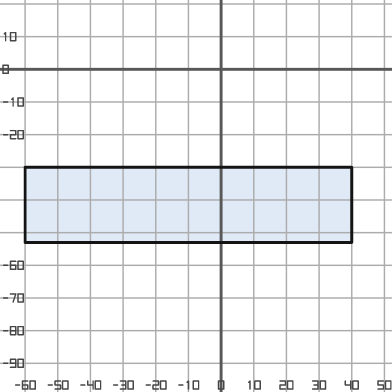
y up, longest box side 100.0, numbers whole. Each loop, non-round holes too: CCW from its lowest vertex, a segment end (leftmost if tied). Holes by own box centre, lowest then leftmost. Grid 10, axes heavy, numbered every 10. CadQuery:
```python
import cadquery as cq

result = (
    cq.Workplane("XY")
    .moveTo(-60.0, -53.0)
    .lineTo(40.0, -53.0)
    .lineTo(40.0, -30.0)
    .lineTo(-60.0, -30.0)
    .close()
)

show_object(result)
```